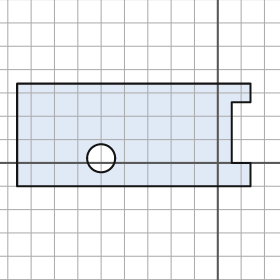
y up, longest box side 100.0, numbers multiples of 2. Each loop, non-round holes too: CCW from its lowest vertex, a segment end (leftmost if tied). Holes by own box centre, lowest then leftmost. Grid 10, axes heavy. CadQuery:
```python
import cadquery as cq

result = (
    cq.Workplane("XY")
    .moveTo(-86.0, -10.0)
    .lineTo(14.0, -10.0)
    .lineTo(14.0, 0.0)
    .lineTo(6.0, 0.0)
    .lineTo(6.0, 26.0)
    .lineTo(14.0, 26.0)
    .lineTo(14.0, 34.0)
    .lineTo(-86.0, 34.0)
    .close()
    .moveTo(-50.0, 2.0)
    .circle(6.0)
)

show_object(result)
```